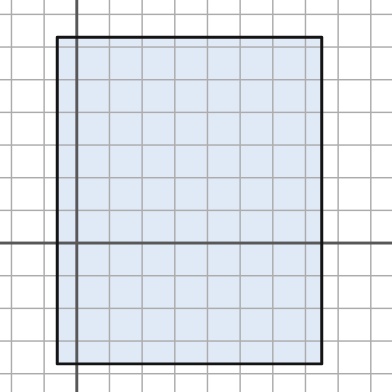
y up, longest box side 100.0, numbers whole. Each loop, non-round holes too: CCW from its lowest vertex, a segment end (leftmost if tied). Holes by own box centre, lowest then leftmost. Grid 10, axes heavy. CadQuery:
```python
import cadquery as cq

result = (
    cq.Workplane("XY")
    .moveTo(-6.0, -37.0)
    .lineTo(75.0, -37.0)
    .lineTo(75.0, 63.0)
    .lineTo(-6.0, 63.0)
    .close()
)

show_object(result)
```